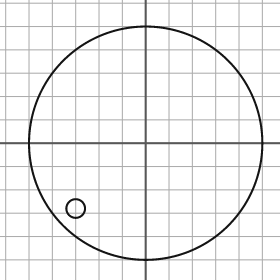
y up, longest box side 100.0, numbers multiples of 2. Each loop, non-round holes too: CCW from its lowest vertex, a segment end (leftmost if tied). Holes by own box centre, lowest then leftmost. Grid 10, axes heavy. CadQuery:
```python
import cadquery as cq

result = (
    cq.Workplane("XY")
    .moveTo(0.0, 0.0)
    .circle(50.0)
    .moveTo(-30.0, -28.0)
    .circle(4.0)
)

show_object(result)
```